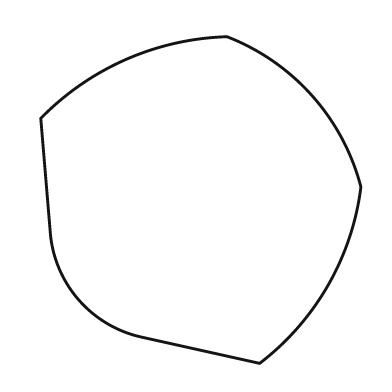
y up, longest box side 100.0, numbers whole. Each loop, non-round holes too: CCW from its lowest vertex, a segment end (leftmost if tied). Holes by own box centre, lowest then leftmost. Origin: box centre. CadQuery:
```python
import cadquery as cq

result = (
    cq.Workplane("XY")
    .moveTo(18.0, -50.0)
    .threePointArc((39.0, -26.0), (49.0, 4.0))
    .threePointArc((34.0, 32.0), (8.0, 50.0))
    .threePointArc((-23.0, 43.0), (-49.0, 25.0))
    .lineTo(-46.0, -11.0)
    .threePointArc((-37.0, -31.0), (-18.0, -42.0))
    .close()
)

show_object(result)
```